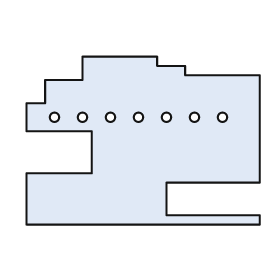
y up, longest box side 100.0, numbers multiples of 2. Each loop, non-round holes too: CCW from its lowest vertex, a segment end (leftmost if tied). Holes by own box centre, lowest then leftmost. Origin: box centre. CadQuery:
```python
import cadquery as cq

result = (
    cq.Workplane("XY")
    .moveTo(-50.0, -36.0)
    .lineTo(50.0, -36.0)
    .lineTo(50.0, -32.0)
    .lineTo(10.0, -32.0)
    .lineTo(10.0, -18.0)
    .lineTo(50.0, -18.0)
    .lineTo(50.0, 28.0)
    .lineTo(18.0, 28.0)
    .lineTo(18.0, 32.0)
    .lineTo(6.0, 32.0)
    .lineTo(6.0, 36.0)
    .lineTo(-26.0, 36.0)
    .lineTo(-26.0, 26.0)
    .lineTo(-42.0, 26.0)
    .lineTo(-42.0, 16.0)
    .lineTo(-50.0, 16.0)
    .lineTo(-50.0, 4.0)
    .lineTo(-22.0, 4.0)
    .lineTo(-22.0, -14.0)
    .lineTo(-50.0, -14.0)
    .close()
    .moveTo(-38.0, 10.0)
    .circle(2.0)
    .moveTo(-26.0, 10.0)
    .circle(2.0)
    .moveTo(-14.0, 10.0)
    .circle(2.0)
    .moveTo(-2.0, 10.0)
    .circle(2.0)
    .moveTo(10.0, 10.0)
    .circle(2.0)
    .moveTo(22.0, 10.0)
    .circle(2.0)
    .moveTo(34.0, 10.0)
    .circle(2.0)
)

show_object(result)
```